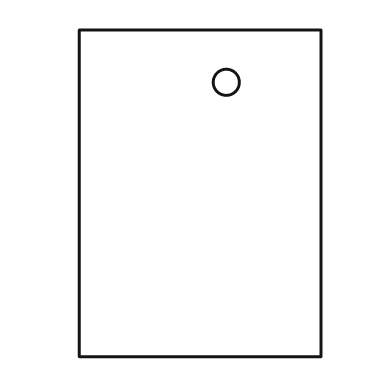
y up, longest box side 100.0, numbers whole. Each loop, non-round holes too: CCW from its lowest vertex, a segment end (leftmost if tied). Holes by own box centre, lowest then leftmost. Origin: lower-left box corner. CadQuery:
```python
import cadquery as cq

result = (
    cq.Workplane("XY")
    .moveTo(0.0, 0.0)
    .lineTo(74.0, 0.0)
    .lineTo(74.0, 100.0)
    .lineTo(0.0, 100.0)
    .close()
    .moveTo(45.0, 84.0)
    .circle(4.0)
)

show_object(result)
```